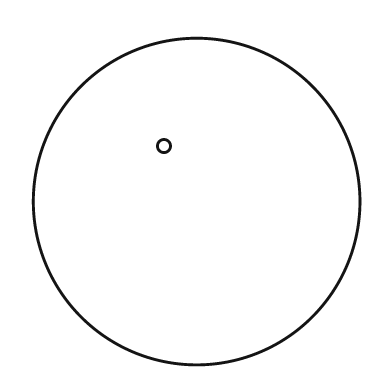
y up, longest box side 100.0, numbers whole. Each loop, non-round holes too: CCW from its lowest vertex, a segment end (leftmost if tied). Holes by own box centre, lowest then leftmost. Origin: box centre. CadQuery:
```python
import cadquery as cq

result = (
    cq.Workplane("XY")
    .moveTo(0.0, 0.0)
    .circle(50.0)
    .moveTo(-10.0, 17.0)
    .circle(2.0)
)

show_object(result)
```